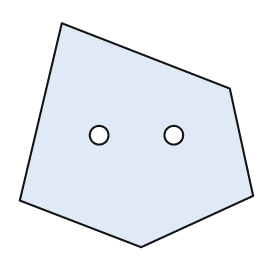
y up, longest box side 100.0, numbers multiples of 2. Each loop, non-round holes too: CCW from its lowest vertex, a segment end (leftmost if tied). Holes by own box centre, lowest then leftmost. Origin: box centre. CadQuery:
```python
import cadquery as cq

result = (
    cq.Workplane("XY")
    .moveTo(2.0, -48.0)
    .lineTo(50.0, -26.0)
    .lineTo(40.0, 20.0)
    .lineTo(-32.0, 48.0)
    .lineTo(-50.0, -28.0)
    .close()
    .moveTo(-16.0, 0.0)
    .circle(4.0)
    .moveTo(16.0, 0.0)
    .circle(4.0)
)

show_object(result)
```